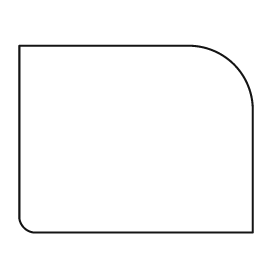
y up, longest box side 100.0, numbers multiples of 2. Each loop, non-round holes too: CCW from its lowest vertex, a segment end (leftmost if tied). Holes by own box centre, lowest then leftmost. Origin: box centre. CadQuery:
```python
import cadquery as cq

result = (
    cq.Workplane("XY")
    .moveTo(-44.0, -40.0)
    .lineTo(50.0, -40.0)
    .lineTo(50.0, 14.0)
    .threePointArc((42.0, 32.0), (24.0, 40.0))
    .lineTo(-50.0, 40.0)
    .lineTo(-50.0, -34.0)
    .threePointArc((-48.0, -38.0), (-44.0, -40.0))
    .close()
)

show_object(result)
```